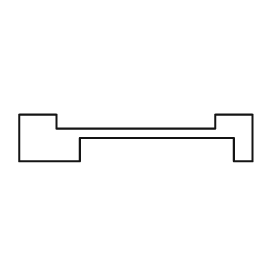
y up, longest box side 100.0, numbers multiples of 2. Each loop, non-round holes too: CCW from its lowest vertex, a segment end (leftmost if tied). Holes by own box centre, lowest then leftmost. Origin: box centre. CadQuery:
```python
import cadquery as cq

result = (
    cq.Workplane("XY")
    .moveTo(-50.0, -10.0)
    .lineTo(-24.0, -10.0)
    .lineTo(-24.0, 0.0)
    .lineTo(42.0, 0.0)
    .lineTo(42.0, -10.0)
    .lineTo(50.0, -10.0)
    .lineTo(50.0, 10.0)
    .lineTo(34.0, 10.0)
    .lineTo(34.0, 4.0)
    .lineTo(-34.0, 4.0)
    .lineTo(-34.0, 10.0)
    .lineTo(-50.0, 10.0)
    .close()
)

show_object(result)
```